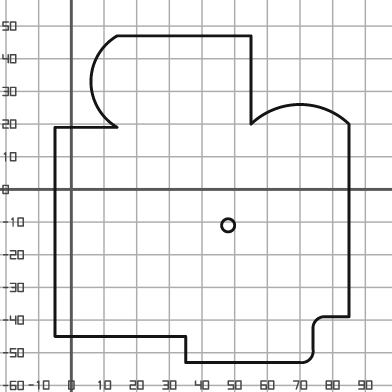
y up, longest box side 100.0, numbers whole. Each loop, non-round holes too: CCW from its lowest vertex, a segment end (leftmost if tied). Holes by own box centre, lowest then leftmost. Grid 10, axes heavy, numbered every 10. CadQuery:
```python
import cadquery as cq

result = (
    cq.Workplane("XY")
    .moveTo(35.0, -53.0)
    .lineTo(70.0, -53.0)
    .threePointArc((73.0, -52.0), (74.0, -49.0))
    .lineTo(74.0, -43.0)
    .threePointArc((75.0, -40.0), (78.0, -39.0))
    .lineTo(85.0, -39.0)
    .lineTo(85.0, 20.0)
    .threePointArc((70.0, 26.0), (55.0, 20.0))
    .lineTo(55.0, 47.0)
    .lineTo(14.0, 47.0)
    .threePointArc((6.0, 33.0), (14.0, 19.0))
    .lineTo(-5.0, 19.0)
    .lineTo(-5.0, -45.0)
    .lineTo(35.0, -45.0)
    .close()
    .moveTo(48.0, -11.0)
    .circle(2.0)
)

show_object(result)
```